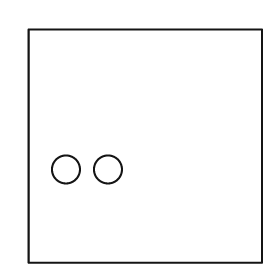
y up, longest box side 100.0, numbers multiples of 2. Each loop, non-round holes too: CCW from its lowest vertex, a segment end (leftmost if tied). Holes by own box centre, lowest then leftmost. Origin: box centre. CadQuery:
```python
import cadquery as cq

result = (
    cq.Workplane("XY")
    .moveTo(-50.0, -50.0)
    .lineTo(50.0, -50.0)
    .lineTo(50.0, 50.0)
    .lineTo(-50.0, 50.0)
    .close()
    .moveTo(-34.0, -10.0)
    .circle(6.0)
    .moveTo(-16.0, -10.0)
    .circle(6.0)
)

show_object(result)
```